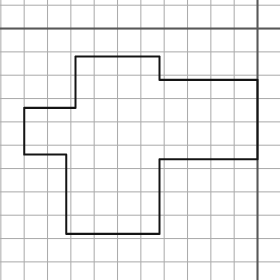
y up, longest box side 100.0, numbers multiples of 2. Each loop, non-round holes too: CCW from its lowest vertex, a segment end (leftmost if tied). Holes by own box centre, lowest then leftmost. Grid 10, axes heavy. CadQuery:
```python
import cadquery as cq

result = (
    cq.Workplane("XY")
    .moveTo(-82.0, -88.0)
    .lineTo(-42.0, -88.0)
    .lineTo(-42.0, -56.0)
    .lineTo(0.0, -56.0)
    .lineTo(0.0, -22.0)
    .lineTo(-42.0, -22.0)
    .lineTo(-42.0, -12.0)
    .lineTo(-78.0, -12.0)
    .lineTo(-78.0, -34.0)
    .lineTo(-100.0, -34.0)
    .lineTo(-100.0, -54.0)
    .lineTo(-82.0, -54.0)
    .close()
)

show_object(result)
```